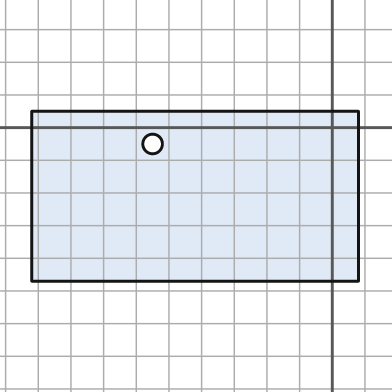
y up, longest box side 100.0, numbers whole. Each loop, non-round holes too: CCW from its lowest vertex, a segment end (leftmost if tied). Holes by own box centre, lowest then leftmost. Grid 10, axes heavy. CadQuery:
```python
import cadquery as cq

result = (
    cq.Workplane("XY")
    .moveTo(-92.0, -47.0)
    .lineTo(8.0, -47.0)
    .lineTo(8.0, 5.0)
    .lineTo(-92.0, 5.0)
    .close()
    .moveTo(-55.0, -5.0)
    .circle(3.0)
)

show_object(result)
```